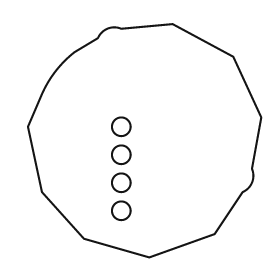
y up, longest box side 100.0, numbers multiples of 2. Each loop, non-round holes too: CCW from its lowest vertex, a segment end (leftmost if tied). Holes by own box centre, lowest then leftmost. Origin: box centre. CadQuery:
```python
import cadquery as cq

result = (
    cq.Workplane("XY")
    .moveTo(2.0, -50.0)
    .lineTo(30.0, -40.0)
    .lineTo(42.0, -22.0)
    .threePointArc((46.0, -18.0), (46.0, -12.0))
    .lineTo(50.0, 10.0)
    .lineTo(38.0, 36.0)
    .lineTo(12.0, 50.0)
    .lineTo(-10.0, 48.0)
    .threePointArc((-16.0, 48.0), (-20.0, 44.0))
    .lineTo(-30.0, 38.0)
    .threePointArc((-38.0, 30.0), (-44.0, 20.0))
    .lineTo(-50.0, 6.0)
    .lineTo(-44.0, -22.0)
    .lineTo(-26.0, -42.0)
    .close()
    .moveTo(-10.0, -30.0)
    .circle(4.0)
    .moveTo(-10.0, -18.0)
    .circle(4.0)
    .moveTo(-10.0, -6.0)
    .circle(4.0)
    .moveTo(-10.0, 6.0)
    .circle(4.0)
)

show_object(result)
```